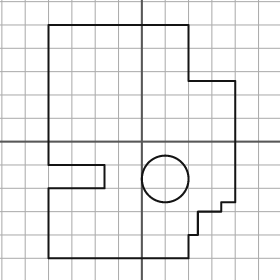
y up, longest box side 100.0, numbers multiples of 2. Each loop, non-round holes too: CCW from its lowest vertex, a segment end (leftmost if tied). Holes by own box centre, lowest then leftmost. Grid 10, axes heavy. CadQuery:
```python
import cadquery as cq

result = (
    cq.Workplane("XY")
    .moveTo(-40.0, -50.0)
    .lineTo(20.0, -50.0)
    .lineTo(20.0, -40.0)
    .lineTo(24.0, -40.0)
    .lineTo(24.0, -30.0)
    .lineTo(34.0, -30.0)
    .lineTo(34.0, -26.0)
    .lineTo(40.0, -26.0)
    .lineTo(40.0, 26.0)
    .lineTo(20.0, 26.0)
    .lineTo(20.0, 50.0)
    .lineTo(-40.0, 50.0)
    .lineTo(-40.0, -10.0)
    .lineTo(-16.0, -10.0)
    .lineTo(-16.0, -20.0)
    .lineTo(-40.0, -20.0)
    .close()
    .moveTo(10.0, -16.0)
    .circle(10.0)
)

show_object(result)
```